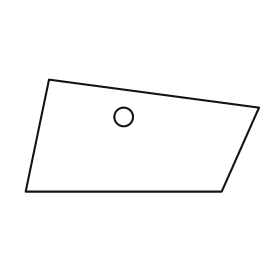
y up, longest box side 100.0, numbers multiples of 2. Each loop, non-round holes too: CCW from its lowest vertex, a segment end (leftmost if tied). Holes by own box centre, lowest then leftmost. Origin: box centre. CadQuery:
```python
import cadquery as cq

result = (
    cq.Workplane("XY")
    .moveTo(-50.0, -24.0)
    .lineTo(34.0, -24.0)
    .lineTo(50.0, 12.0)
    .lineTo(-40.0, 24.0)
    .close()
    .moveTo(-8.0, 8.0)
    .circle(4.0)
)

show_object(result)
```